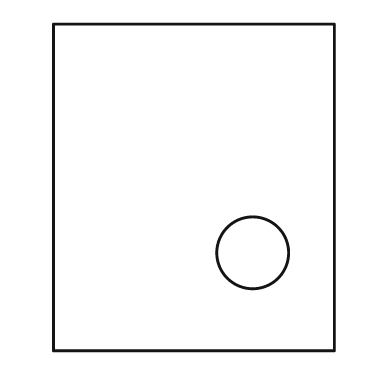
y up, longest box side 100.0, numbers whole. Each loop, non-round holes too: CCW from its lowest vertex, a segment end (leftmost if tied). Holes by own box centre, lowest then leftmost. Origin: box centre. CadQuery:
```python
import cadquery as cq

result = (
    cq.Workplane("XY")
    .moveTo(-43.0, -50.0)
    .lineTo(43.0, -50.0)
    .lineTo(43.0, 50.0)
    .lineTo(-43.0, 50.0)
    .close()
    .moveTo(18.0, -20.0)
    .circle(11.0)
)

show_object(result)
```